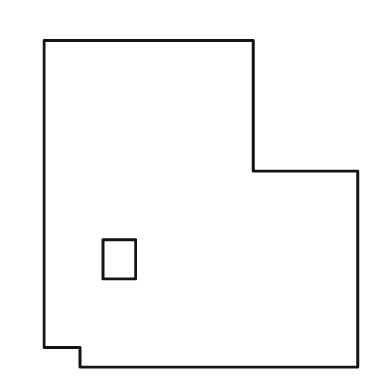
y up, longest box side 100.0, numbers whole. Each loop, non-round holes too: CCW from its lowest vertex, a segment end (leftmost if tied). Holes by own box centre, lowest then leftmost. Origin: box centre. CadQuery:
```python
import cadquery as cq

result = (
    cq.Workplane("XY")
    .moveTo(-37.0, -50.0)
    .lineTo(48.0, -50.0)
    .lineTo(48.0, 10.0)
    .lineTo(16.0, 10.0)
    .lineTo(16.0, 50.0)
    .lineTo(-48.0, 50.0)
    .lineTo(-48.0, -44.0)
    .lineTo(-37.0, -44.0)
    .close()
    .moveTo(-30.0, -23.0)
    .lineTo(-20.0, -23.0)
    .lineTo(-20.0, -11.0)
    .lineTo(-30.0, -11.0)
    .close()
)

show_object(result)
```